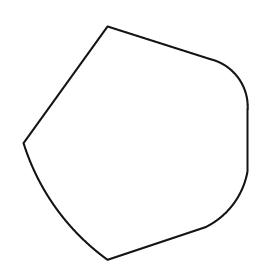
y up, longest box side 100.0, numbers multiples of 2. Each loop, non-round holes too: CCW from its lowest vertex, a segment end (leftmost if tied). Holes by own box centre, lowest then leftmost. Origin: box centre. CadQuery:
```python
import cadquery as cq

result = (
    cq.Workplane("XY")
    .moveTo(-12.0, -50.0)
    .lineTo(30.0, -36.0)
    .threePointArc((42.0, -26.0), (48.0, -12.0))
    .lineTo(48.0, 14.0)
    .threePointArc((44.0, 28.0), (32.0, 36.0))
    .lineTo(-12.0, 50.0)
    .lineTo(-48.0, 0.0)
    .threePointArc((-34.0, -28.0), (-12.0, -50.0))
    .close()
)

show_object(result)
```